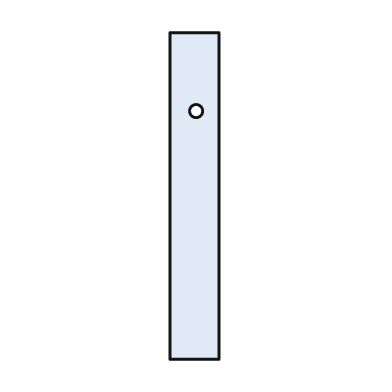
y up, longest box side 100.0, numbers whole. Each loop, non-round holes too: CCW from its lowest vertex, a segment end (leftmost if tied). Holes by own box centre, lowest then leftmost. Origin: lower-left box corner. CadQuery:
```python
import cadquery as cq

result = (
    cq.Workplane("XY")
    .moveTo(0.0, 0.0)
    .lineTo(15.0, 0.0)
    .lineTo(15.0, 100.0)
    .lineTo(0.0, 100.0)
    .close()
    .moveTo(8.0, 76.0)
    .circle(2.0)
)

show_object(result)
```